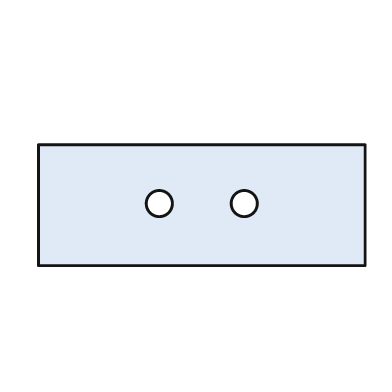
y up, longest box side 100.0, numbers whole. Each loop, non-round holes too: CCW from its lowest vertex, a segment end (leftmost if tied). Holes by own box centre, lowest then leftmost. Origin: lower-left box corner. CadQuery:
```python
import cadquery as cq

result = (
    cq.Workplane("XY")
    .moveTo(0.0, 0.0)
    .lineTo(100.0, 0.0)
    .lineTo(100.0, 37.0)
    .lineTo(0.0, 37.0)
    .close()
    .moveTo(37.0, 19.0)
    .circle(4.0)
    .moveTo(63.0, 19.0)
    .circle(4.0)
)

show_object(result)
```